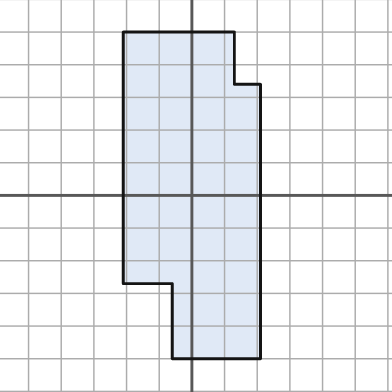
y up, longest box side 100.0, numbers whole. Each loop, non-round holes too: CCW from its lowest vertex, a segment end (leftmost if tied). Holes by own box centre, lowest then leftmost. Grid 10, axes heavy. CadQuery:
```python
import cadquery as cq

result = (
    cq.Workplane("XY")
    .moveTo(-6.0, -50.0)
    .lineTo(21.0, -50.0)
    .lineTo(21.0, 34.0)
    .lineTo(13.0, 34.0)
    .lineTo(13.0, 50.0)
    .lineTo(-21.0, 50.0)
    .lineTo(-21.0, -27.0)
    .lineTo(-6.0, -27.0)
    .close()
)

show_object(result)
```